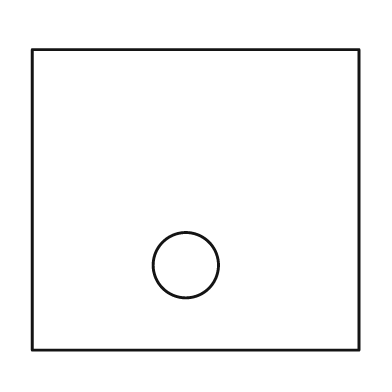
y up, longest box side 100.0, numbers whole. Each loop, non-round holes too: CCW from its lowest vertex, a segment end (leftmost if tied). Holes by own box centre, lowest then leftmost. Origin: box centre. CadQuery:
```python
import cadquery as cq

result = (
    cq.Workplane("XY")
    .moveTo(-50.0, -46.0)
    .lineTo(50.0, -46.0)
    .lineTo(50.0, 46.0)
    .lineTo(-50.0, 46.0)
    .close()
    .moveTo(-3.0, -20.0)
    .circle(10.0)
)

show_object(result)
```